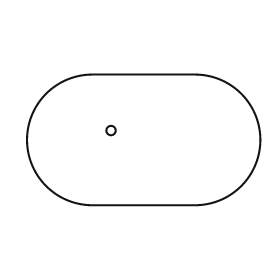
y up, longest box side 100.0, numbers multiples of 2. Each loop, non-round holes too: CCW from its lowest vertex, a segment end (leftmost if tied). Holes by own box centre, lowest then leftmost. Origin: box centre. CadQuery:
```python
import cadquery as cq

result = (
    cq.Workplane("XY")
    .moveTo(-22.0, -28.0)
    .lineTo(22.0, -28.0)
    .threePointArc((50.0, 0.0), (22.0, 28.0))
    .lineTo(-22.0, 28.0)
    .threePointArc((-50.0, 0.0), (-22.0, -28.0))
    .close()
    .moveTo(-14.0, 4.0)
    .circle(2.0)
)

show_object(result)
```